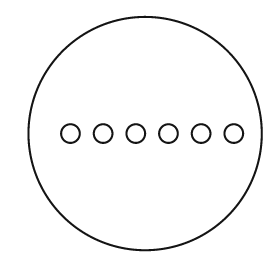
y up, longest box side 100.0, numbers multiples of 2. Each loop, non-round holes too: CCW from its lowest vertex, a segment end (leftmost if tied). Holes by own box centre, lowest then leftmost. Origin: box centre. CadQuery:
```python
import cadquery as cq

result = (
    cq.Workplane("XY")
    .moveTo(0.0, 0.0)
    .circle(50.0)
    .moveTo(-32.0, 0.0)
    .circle(4.0)
    .moveTo(-18.0, 0.0)
    .circle(4.0)
    .moveTo(-4.0, 0.0)
    .circle(4.0)
    .moveTo(10.0, 0.0)
    .circle(4.0)
    .moveTo(24.0, 0.0)
    .circle(4.0)
    .moveTo(38.0, 0.0)
    .circle(4.0)
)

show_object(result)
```